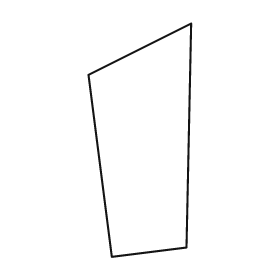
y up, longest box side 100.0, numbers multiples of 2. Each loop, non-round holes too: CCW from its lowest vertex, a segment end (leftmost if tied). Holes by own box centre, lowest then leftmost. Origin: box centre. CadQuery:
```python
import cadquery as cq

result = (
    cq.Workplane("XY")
    .moveTo(-12.0, -50.0)
    .lineTo(20.0, -46.0)
    .lineTo(22.0, 50.0)
    .lineTo(-22.0, 28.0)
    .close()
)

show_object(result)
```